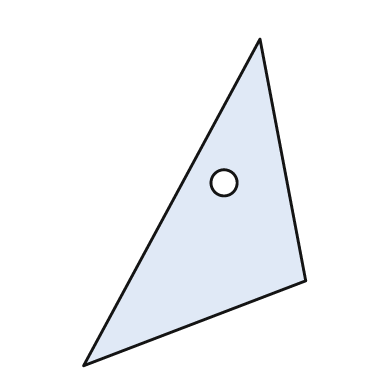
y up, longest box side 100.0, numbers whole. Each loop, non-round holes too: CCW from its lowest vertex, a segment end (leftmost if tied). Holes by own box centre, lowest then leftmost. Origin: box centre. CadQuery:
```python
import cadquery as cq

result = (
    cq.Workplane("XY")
    .moveTo(-34.0, -50.0)
    .lineTo(34.0, -24.0)
    .lineTo(20.0, 50.0)
    .close()
    .moveTo(9.0, 6.0)
    .circle(4.0)
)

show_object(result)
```